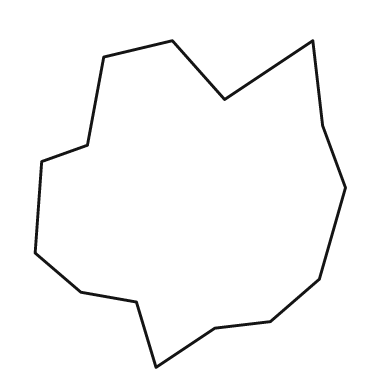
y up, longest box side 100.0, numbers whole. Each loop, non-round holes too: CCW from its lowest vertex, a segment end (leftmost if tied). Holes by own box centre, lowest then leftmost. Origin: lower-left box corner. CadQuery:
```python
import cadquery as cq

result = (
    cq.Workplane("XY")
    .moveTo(37.0, 0.0)
    .lineTo(55.0, 12.0)
    .lineTo(72.0, 14.0)
    .lineTo(87.0, 27.0)
    .lineTo(95.0, 55.0)
    .lineTo(88.0, 74.0)
    .lineTo(85.0, 100.0)
    .lineTo(58.0, 82.0)
    .lineTo(42.0, 100.0)
    .lineTo(21.0, 95.0)
    .lineTo(16.0, 68.0)
    .lineTo(2.0, 63.0)
    .lineTo(0.0, 35.0)
    .lineTo(14.0, 23.0)
    .lineTo(31.0, 20.0)
    .close()
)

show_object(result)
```